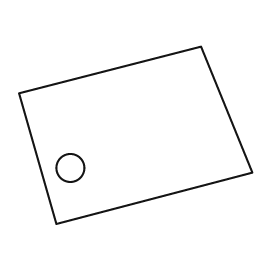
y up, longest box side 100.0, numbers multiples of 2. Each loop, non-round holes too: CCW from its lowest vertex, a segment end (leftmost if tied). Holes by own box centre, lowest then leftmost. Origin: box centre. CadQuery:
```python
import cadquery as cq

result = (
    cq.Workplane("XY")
    .moveTo(-34.0, -38.0)
    .lineTo(50.0, -16.0)
    .lineTo(28.0, 38.0)
    .lineTo(-50.0, 18.0)
    .close()
    .moveTo(-28.0, -14.0)
    .circle(6.0)
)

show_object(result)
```